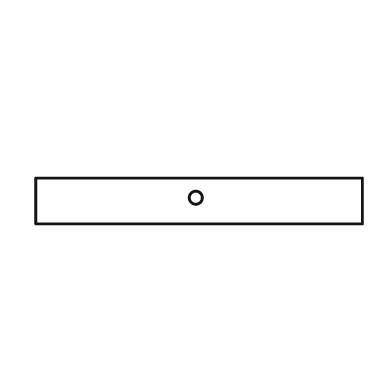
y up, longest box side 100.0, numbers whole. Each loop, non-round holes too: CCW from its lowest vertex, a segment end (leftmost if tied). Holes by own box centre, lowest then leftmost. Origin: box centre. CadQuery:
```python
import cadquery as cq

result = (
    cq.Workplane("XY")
    .moveTo(-50.0, -7.0)
    .lineTo(50.0, -7.0)
    .lineTo(50.0, 7.0)
    .lineTo(-50.0, 7.0)
    .close()
    .moveTo(-1.0, 1.0)
    .circle(2.0)
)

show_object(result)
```